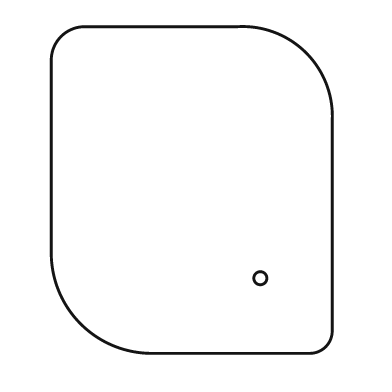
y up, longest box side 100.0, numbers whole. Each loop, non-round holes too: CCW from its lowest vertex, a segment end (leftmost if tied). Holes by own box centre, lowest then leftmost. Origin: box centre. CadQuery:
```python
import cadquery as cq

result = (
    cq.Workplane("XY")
    .moveTo(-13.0, -50.0)
    .lineTo(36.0, -50.0)
    .threePointArc((41.0, -48.0), (43.0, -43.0))
    .lineTo(43.0, 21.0)
    .threePointArc((35.0, 42.0), (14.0, 50.0))
    .lineTo(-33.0, 50.0)
    .threePointArc((-40.0, 47.0), (-43.0, 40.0))
    .lineTo(-43.0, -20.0)
    .threePointArc((-34.0, -41.0), (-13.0, -50.0))
    .close()
    .moveTo(21.0, -27.0)
    .circle(2.0)
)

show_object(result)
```